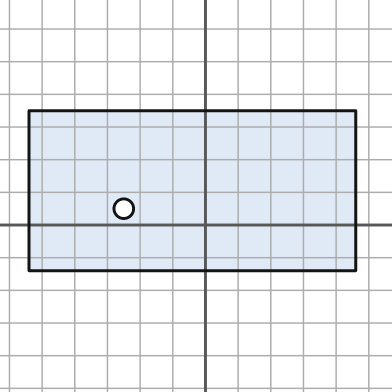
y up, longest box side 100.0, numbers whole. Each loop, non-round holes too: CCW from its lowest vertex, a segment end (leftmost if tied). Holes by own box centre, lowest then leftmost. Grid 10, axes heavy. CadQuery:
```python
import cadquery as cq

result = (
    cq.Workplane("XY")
    .moveTo(-54.0, -14.0)
    .lineTo(46.0, -14.0)
    .lineTo(46.0, 35.0)
    .lineTo(-54.0, 35.0)
    .close()
    .moveTo(-25.0, 5.0)
    .circle(3.0)
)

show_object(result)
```